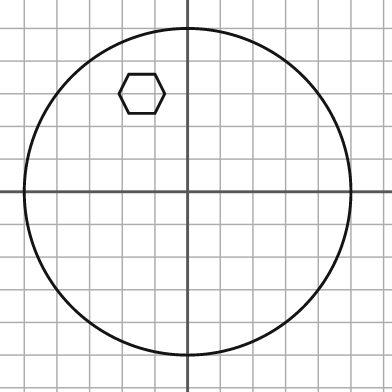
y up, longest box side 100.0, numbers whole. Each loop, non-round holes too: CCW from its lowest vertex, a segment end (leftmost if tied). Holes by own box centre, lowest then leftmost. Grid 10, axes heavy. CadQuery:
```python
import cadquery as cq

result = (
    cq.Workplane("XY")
    .moveTo(0.0, 0.0)
    .circle(50.0)
    .moveTo(-18.0, 24.0)
    .lineTo(-10.0, 24.0)
    .lineTo(-7.0, 30.0)
    .lineTo(-10.0, 36.0)
    .lineTo(-18.0, 36.0)
    .lineTo(-21.0, 30.0)
    .close()
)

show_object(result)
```